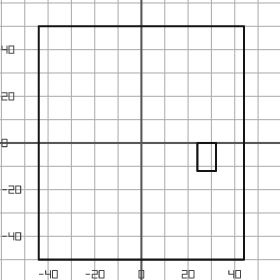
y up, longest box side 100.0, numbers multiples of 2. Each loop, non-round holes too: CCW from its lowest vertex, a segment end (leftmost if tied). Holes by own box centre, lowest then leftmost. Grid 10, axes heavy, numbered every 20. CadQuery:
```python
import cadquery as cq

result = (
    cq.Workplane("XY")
    .moveTo(-44.0, -50.0)
    .lineTo(44.0, -50.0)
    .lineTo(44.0, 50.0)
    .lineTo(-44.0, 50.0)
    .close()
    .moveTo(24.0, -12.0)
    .lineTo(32.0, -12.0)
    .lineTo(32.0, 0.0)
    .lineTo(24.0, 0.0)
    .close()
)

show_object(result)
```